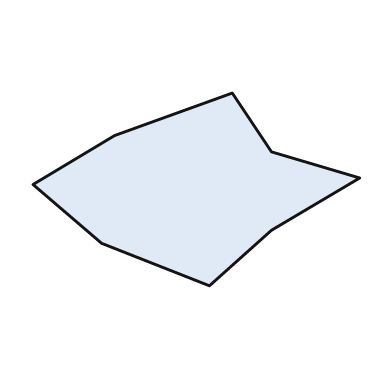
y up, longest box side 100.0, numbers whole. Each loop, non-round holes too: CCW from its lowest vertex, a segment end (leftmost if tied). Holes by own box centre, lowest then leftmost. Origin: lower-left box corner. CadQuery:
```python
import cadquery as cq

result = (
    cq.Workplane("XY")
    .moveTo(54.0, 0.0)
    .lineTo(73.0, 17.0)
    .lineTo(100.0, 33.0)
    .lineTo(73.0, 41.0)
    .lineTo(61.0, 59.0)
    .lineTo(25.0, 46.0)
    .lineTo(0.0, 31.0)
    .lineTo(21.0, 13.0)
    .close()
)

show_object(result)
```